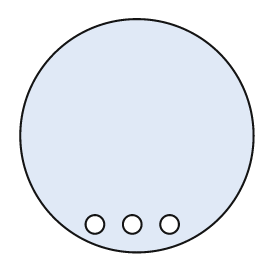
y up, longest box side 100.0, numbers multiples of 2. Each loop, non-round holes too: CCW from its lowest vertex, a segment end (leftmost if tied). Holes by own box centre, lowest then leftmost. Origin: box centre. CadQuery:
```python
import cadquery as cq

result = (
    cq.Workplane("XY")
    .moveTo(0.0, 0.0)
    .circle(50.0)
    .moveTo(-18.0, -38.0)
    .circle(4.0)
    .moveTo(-2.0, -38.0)
    .circle(4.0)
    .moveTo(14.0, -38.0)
    .circle(4.0)
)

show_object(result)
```